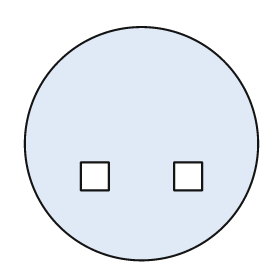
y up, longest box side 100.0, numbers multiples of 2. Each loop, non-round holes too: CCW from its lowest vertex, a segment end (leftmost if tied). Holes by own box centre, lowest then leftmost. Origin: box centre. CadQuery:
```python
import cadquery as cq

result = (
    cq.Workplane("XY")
    .moveTo(0.0, 0.0)
    .circle(50.0)
    .moveTo(-26.0, -20.0)
    .lineTo(-14.0, -20.0)
    .lineTo(-14.0, -8.0)
    .lineTo(-26.0, -8.0)
    .close()
    .moveTo(14.0, -20.0)
    .lineTo(26.0, -20.0)
    .lineTo(26.0, -8.0)
    .lineTo(14.0, -8.0)
    .close()
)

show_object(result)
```